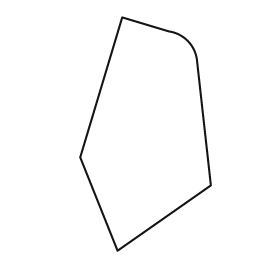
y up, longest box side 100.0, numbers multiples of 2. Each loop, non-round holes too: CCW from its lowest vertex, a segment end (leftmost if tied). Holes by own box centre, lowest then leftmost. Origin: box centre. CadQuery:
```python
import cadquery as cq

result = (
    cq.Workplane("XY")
    .moveTo(-12.0, -50.0)
    .lineTo(28.0, -22.0)
    .lineTo(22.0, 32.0)
    .threePointArc((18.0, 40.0), (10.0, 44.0))
    .lineTo(-10.0, 50.0)
    .lineTo(-28.0, -10.0)
    .close()
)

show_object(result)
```